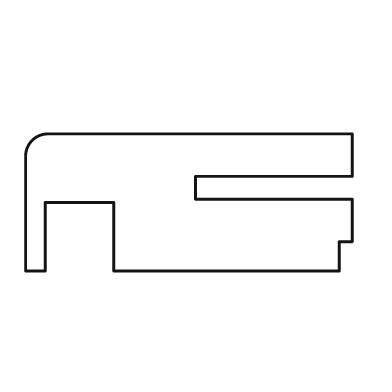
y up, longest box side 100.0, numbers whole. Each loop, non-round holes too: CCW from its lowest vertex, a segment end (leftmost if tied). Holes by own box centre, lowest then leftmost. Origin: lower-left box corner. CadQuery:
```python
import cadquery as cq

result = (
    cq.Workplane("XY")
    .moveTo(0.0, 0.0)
    .lineTo(6.0, 0.0)
    .lineTo(6.0, 21.0)
    .lineTo(27.0, 21.0)
    .lineTo(27.0, 0.0)
    .lineTo(96.0, 0.0)
    .lineTo(96.0, 9.0)
    .lineTo(100.0, 9.0)
    .lineTo(100.0, 22.0)
    .lineTo(52.0, 22.0)
    .lineTo(52.0, 29.0)
    .lineTo(100.0, 29.0)
    .lineTo(100.0, 42.0)
    .lineTo(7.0, 42.0)
    .threePointArc((2.0, 40.0), (0.0, 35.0))
    .close()
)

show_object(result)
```